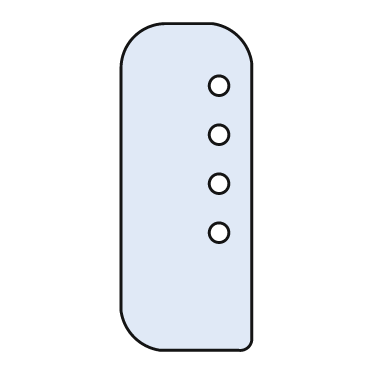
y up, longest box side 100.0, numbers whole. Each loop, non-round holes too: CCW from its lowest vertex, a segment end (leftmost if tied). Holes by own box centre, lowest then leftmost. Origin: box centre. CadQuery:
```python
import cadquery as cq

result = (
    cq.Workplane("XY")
    .moveTo(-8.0, -50.0)
    .lineTo(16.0, -50.0)
    .threePointArc((19.0, -49.0), (20.0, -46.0))
    .lineTo(20.0, 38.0)
    .threePointArc((16.0, 46.0), (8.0, 50.0))
    .lineTo(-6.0, 50.0)
    .threePointArc((-16.0, 46.0), (-20.0, 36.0))
    .lineTo(-20.0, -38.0)
    .threePointArc((-16.0, -46.0), (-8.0, -50.0))
    .close()
    .moveTo(10.0, -14.0)
    .circle(3.0)
    .moveTo(10.0, 1.0)
    .circle(3.0)
    .moveTo(10.0, 16.0)
    .circle(3.0)
    .moveTo(10.0, 31.0)
    .circle(3.0)
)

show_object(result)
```